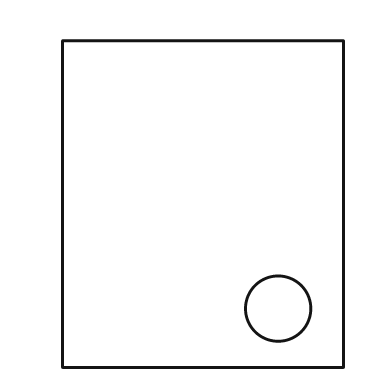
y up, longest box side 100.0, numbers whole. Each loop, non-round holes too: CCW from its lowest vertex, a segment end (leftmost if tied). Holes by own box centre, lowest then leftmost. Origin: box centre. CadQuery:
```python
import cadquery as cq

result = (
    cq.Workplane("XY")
    .moveTo(-43.0, -50.0)
    .lineTo(43.0, -50.0)
    .lineTo(43.0, 50.0)
    .lineTo(-43.0, 50.0)
    .close()
    .moveTo(23.0, -32.0)
    .circle(10.0)
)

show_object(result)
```